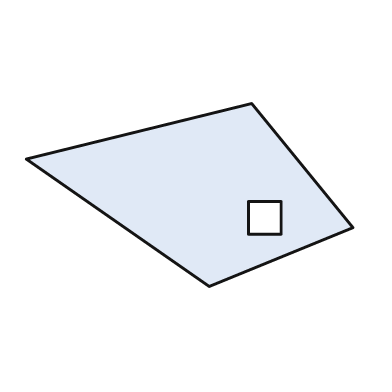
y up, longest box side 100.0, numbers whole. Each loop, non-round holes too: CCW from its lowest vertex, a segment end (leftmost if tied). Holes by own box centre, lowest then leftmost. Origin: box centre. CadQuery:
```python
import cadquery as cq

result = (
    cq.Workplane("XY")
    .moveTo(6.0, -28.0)
    .lineTo(50.0, -10.0)
    .lineTo(19.0, 28.0)
    .lineTo(-50.0, 11.0)
    .close()
    .moveTo(18.0, -12.0)
    .lineTo(28.0, -12.0)
    .lineTo(28.0, -2.0)
    .lineTo(18.0, -2.0)
    .close()
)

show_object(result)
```